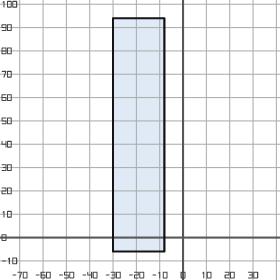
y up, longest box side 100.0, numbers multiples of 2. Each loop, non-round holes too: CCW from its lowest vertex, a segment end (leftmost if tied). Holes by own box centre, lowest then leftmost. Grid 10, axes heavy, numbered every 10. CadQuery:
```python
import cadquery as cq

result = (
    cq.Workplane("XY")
    .moveTo(-30.0, -6.0)
    .lineTo(-8.0, -6.0)
    .lineTo(-8.0, 94.0)
    .lineTo(-30.0, 94.0)
    .close()
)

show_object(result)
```